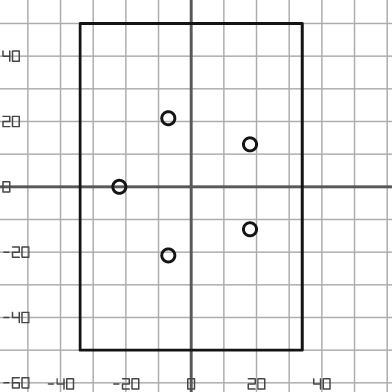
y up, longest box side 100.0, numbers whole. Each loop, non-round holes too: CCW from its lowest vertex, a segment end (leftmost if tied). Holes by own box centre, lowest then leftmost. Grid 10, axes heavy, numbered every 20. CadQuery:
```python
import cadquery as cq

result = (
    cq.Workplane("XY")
    .moveTo(-34.0, -50.0)
    .lineTo(34.0, -50.0)
    .lineTo(34.0, 50.0)
    .lineTo(-34.0, 50.0)
    .close()
    .moveTo(-7.0, -21.0)
    .circle(2.0)
    .moveTo(18.0, -13.0)
    .circle(2.0)
    .moveTo(-22.0, 0.0)
    .circle(2.0)
    .moveTo(18.0, 13.0)
    .circle(2.0)
    .moveTo(-7.0, 21.0)
    .circle(2.0)
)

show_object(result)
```